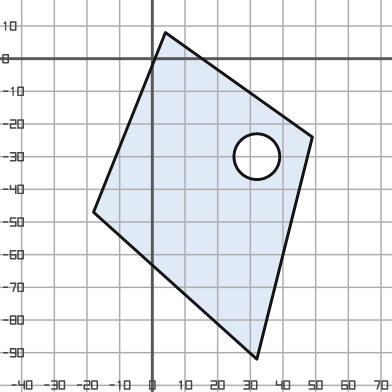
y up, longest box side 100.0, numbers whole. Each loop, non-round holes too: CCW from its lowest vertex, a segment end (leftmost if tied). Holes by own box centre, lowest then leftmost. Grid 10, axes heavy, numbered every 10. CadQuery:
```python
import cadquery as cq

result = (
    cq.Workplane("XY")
    .moveTo(32.0, -92.0)
    .lineTo(49.0, -24.0)
    .lineTo(4.0, 8.0)
    .lineTo(-18.0, -47.0)
    .close()
    .moveTo(32.0, -30.0)
    .circle(7.0)
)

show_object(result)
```